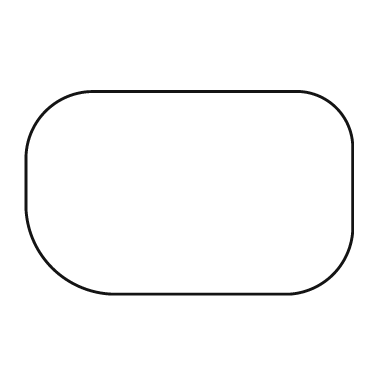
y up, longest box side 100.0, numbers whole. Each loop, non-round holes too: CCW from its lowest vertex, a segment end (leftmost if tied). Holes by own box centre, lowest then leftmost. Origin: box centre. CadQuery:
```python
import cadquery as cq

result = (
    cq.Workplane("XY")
    .moveTo(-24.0, -31.0)
    .lineTo(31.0, -31.0)
    .threePointArc((44.0, -25.0), (50.0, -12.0))
    .lineTo(50.0, 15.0)
    .threePointArc((45.0, 26.0), (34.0, 31.0))
    .lineTo(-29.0, 31.0)
    .threePointArc((-44.0, 25.0), (-50.0, 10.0))
    .lineTo(-50.0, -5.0)
    .threePointArc((-42.0, -23.0), (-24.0, -31.0))
    .close()
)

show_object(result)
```